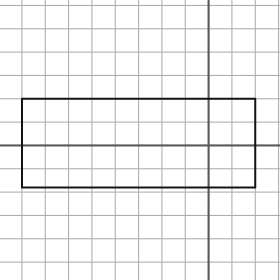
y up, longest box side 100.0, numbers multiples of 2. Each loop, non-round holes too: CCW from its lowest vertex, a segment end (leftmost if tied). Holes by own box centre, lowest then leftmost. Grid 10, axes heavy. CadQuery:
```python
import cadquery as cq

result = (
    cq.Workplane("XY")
    .moveTo(-80.0, -18.0)
    .lineTo(20.0, -18.0)
    .lineTo(20.0, 20.0)
    .lineTo(-80.0, 20.0)
    .close()
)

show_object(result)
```